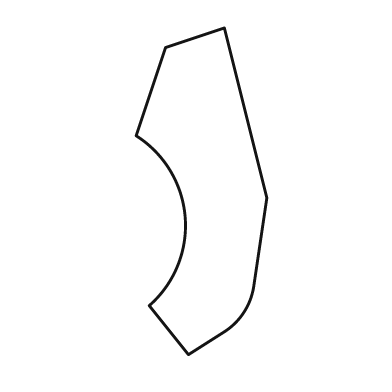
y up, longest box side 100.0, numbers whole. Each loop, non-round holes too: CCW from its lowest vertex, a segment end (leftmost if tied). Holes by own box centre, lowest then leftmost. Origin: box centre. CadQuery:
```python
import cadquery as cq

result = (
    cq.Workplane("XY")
    .moveTo(-4.0, -50.0)
    .lineTo(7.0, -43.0)
    .threePointArc((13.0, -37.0), (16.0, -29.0))
    .lineTo(20.0, -2.0)
    .lineTo(7.0, 50.0)
    .lineTo(-11.0, 44.0)
    .lineTo(-20.0, 17.0)
    .threePointArc((-5.0, -8.0), (-16.0, -35.0))
    .close()
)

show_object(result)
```